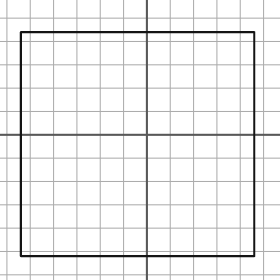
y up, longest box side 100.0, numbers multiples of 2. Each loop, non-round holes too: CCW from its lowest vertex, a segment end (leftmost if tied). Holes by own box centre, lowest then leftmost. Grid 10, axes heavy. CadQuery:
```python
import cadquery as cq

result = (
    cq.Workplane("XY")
    .moveTo(-54.0, -52.0)
    .lineTo(46.0, -52.0)
    .lineTo(46.0, 44.0)
    .lineTo(-54.0, 44.0)
    .close()
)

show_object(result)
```